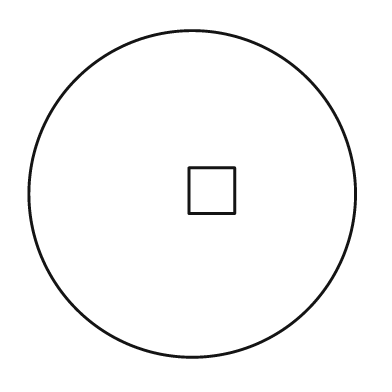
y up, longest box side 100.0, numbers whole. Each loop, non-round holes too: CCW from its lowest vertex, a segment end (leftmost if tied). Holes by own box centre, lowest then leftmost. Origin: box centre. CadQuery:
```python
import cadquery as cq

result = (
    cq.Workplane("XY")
    .moveTo(0.0, 0.0)
    .circle(50.0)
    .moveTo(-1.0, -6.0)
    .lineTo(13.0, -6.0)
    .lineTo(13.0, 8.0)
    .lineTo(-1.0, 8.0)
    .close()
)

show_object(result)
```